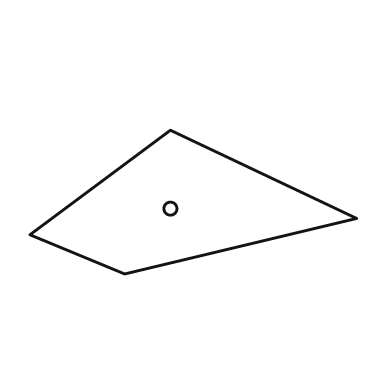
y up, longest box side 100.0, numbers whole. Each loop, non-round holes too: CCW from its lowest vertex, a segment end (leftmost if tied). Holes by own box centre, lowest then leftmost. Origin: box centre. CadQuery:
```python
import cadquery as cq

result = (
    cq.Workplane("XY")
    .moveTo(-21.0, -22.0)
    .lineTo(50.0, -5.0)
    .lineTo(-7.0, 22.0)
    .lineTo(-50.0, -10.0)
    .close()
    .moveTo(-7.0, -2.0)
    .circle(2.0)
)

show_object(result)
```